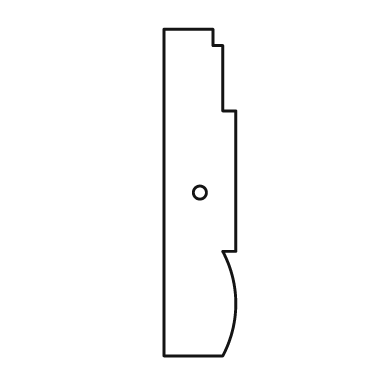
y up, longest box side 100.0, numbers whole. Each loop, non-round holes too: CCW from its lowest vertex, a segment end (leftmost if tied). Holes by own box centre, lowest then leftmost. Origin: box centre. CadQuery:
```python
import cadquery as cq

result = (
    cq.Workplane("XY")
    .moveTo(-11.0, -50.0)
    .lineTo(7.0, -50.0)
    .threePointArc((11.0, -34.0), (7.0, -18.0))
    .lineTo(11.0, -18.0)
    .lineTo(11.0, 25.0)
    .lineTo(7.0, 25.0)
    .lineTo(7.0, 45.0)
    .lineTo(4.0, 45.0)
    .lineTo(4.0, 50.0)
    .lineTo(-11.0, 50.0)
    .close()
    .moveTo(0.0, 0.0)
    .circle(2.0)
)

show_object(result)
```